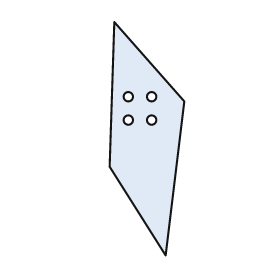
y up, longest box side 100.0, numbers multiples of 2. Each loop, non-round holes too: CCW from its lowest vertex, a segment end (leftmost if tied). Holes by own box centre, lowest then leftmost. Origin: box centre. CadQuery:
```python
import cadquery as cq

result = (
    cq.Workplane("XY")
    .moveTo(8.0, -50.0)
    .lineTo(16.0, 16.0)
    .lineTo(-14.0, 50.0)
    .lineTo(-16.0, -12.0)
    .close()
    .moveTo(-8.0, 8.0)
    .circle(2.0)
    .moveTo(2.0, 8.0)
    .circle(2.0)
    .moveTo(-8.0, 18.0)
    .circle(2.0)
    .moveTo(2.0, 18.0)
    .circle(2.0)
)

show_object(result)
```